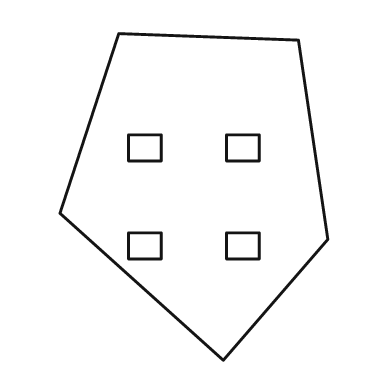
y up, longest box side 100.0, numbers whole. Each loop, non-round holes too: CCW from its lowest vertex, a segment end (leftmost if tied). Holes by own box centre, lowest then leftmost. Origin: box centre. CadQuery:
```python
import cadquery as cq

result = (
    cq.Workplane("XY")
    .moveTo(9.0, -50.0)
    .lineTo(41.0, -13.0)
    .lineTo(32.0, 48.0)
    .lineTo(-23.0, 50.0)
    .lineTo(-41.0, -5.0)
    .close()
    .moveTo(-20.0, -19.0)
    .lineTo(-10.0, -19.0)
    .lineTo(-10.0, -11.0)
    .lineTo(-20.0, -11.0)
    .close()
    .moveTo(10.0, -19.0)
    .lineTo(20.0, -19.0)
    .lineTo(20.0, -11.0)
    .lineTo(10.0, -11.0)
    .close()
    .moveTo(-20.0, 11.0)
    .lineTo(-10.0, 11.0)
    .lineTo(-10.0, 19.0)
    .lineTo(-20.0, 19.0)
    .close()
    .moveTo(10.0, 11.0)
    .lineTo(20.0, 11.0)
    .lineTo(20.0, 19.0)
    .lineTo(10.0, 19.0)
    .close()
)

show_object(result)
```